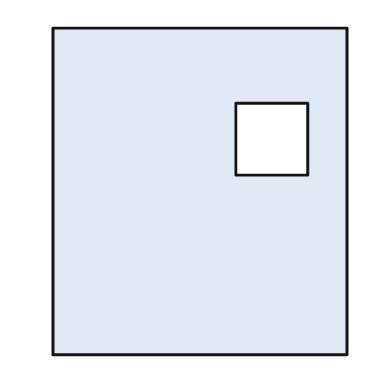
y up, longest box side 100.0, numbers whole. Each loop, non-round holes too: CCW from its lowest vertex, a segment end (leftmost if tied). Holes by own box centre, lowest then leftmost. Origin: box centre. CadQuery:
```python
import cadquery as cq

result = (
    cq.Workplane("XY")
    .moveTo(-45.0, -50.0)
    .lineTo(45.0, -50.0)
    .lineTo(45.0, 50.0)
    .lineTo(-45.0, 50.0)
    .close()
    .moveTo(11.0, 5.0)
    .lineTo(33.0, 5.0)
    .lineTo(33.0, 27.0)
    .lineTo(11.0, 27.0)
    .close()
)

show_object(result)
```